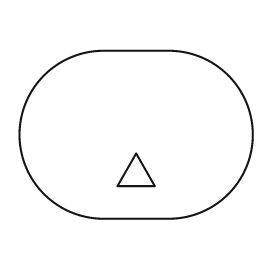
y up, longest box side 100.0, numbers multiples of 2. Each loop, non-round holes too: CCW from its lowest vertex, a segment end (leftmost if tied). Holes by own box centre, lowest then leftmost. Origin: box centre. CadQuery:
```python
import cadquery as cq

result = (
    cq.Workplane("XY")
    .moveTo(-14.0, -36.0)
    .lineTo(14.0, -36.0)
    .threePointArc((50.0, 0.0), (14.0, 36.0))
    .lineTo(-14.0, 36.0)
    .threePointArc((-50.0, 0.0), (-14.0, -36.0))
    .close()
    .moveTo(-8.0, -22.0)
    .lineTo(8.0, -22.0)
    .lineTo(0.0, -8.0)
    .close()
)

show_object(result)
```